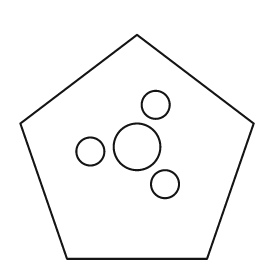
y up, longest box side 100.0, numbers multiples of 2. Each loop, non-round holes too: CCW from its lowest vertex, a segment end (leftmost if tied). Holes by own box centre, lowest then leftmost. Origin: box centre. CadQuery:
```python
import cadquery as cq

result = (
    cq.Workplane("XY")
    .moveTo(-30.0, -48.0)
    .lineTo(30.0, -48.0)
    .lineTo(50.0, 10.0)
    .lineTo(0.0, 48.0)
    .lineTo(-50.0, 10.0)
    .close()
    .moveTo(12.0, -16.0)
    .circle(6.0)
    .moveTo(-20.0, -2.0)
    .circle(6.0)
    .moveTo(0.0, 0.0)
    .circle(10.0)
    .moveTo(8.0, 18.0)
    .circle(6.0)
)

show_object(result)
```